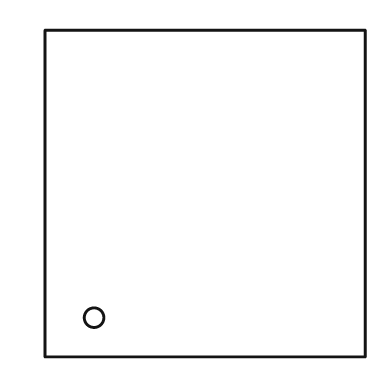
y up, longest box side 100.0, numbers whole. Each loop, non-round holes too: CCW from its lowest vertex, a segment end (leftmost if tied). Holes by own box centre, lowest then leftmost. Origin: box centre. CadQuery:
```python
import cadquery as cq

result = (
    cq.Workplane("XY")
    .moveTo(-49.0, -50.0)
    .lineTo(49.0, -50.0)
    .lineTo(49.0, 50.0)
    .lineTo(-49.0, 50.0)
    .close()
    .moveTo(-34.0, -38.0)
    .circle(3.0)
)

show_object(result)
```